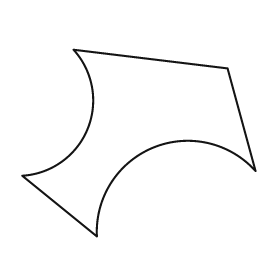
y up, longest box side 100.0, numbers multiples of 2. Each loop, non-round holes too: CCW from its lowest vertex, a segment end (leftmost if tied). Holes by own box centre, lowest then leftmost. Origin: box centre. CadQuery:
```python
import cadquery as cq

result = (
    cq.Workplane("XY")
    .moveTo(-18.0, -40.0)
    .threePointArc((6.0, -2.0), (50.0, -12.0))
    .lineTo(38.0, 32.0)
    .lineTo(-28.0, 40.0)
    .threePointArc((-22.0, 6.0), (-50.0, -14.0))
    .close()
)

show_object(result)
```